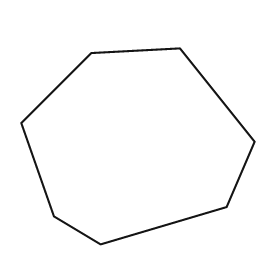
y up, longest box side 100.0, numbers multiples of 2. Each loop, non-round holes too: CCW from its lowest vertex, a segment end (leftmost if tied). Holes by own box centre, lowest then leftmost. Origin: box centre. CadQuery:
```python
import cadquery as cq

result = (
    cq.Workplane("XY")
    .moveTo(-16.0, -42.0)
    .lineTo(38.0, -26.0)
    .lineTo(50.0, 2.0)
    .lineTo(18.0, 42.0)
    .lineTo(-20.0, 40.0)
    .lineTo(-50.0, 10.0)
    .lineTo(-36.0, -30.0)
    .close()
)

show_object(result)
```